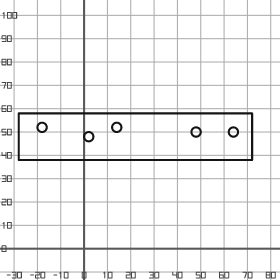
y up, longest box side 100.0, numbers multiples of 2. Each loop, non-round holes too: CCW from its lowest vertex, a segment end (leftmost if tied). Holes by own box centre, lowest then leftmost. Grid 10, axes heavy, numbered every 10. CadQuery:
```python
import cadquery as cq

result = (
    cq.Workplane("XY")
    .moveTo(-28.0, 38.0)
    .lineTo(72.0, 38.0)
    .lineTo(72.0, 58.0)
    .lineTo(-28.0, 58.0)
    .close()
    .moveTo(2.0, 48.0)
    .circle(2.0)
    .moveTo(48.0, 50.0)
    .circle(2.0)
    .moveTo(64.0, 50.0)
    .circle(2.0)
    .moveTo(-18.0, 52.0)
    .circle(2.0)
    .moveTo(14.0, 52.0)
    .circle(2.0)
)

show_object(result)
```